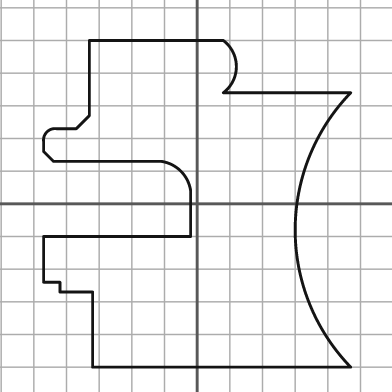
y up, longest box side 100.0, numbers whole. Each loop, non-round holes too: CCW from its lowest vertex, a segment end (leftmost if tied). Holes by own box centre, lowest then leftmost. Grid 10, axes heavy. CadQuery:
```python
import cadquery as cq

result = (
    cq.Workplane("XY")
    .moveTo(-32.0, -50.0)
    .lineTo(47.0, -50.0)
    .threePointArc((30.0, -8.0), (47.0, 34.0))
    .lineTo(8.0, 34.0)
    .threePointArc((12.0, 42.0), (8.0, 50.0))
    .lineTo(-33.0, 50.0)
    .lineTo(-33.0, 27.0)
    .lineTo(-37.0, 23.0)
    .lineTo(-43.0, 23.0)
    .threePointArc((-46.0, 22.0), (-47.0, 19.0))
    .lineTo(-47.0, 16.0)
    .lineTo(-44.0, 13.0)
    .lineTo(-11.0, 13.0)
    .threePointArc((-5.0, 10.0), (-2.0, 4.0))
    .lineTo(-2.0, -10.0)
    .lineTo(-47.0, -10.0)
    .lineTo(-47.0, -24.0)
    .lineTo(-42.0, -24.0)
    .lineTo(-42.0, -27.0)
    .lineTo(-32.0, -27.0)
    .close()
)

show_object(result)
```